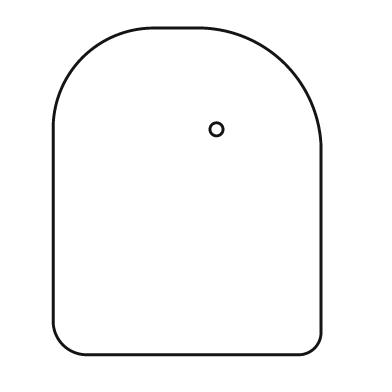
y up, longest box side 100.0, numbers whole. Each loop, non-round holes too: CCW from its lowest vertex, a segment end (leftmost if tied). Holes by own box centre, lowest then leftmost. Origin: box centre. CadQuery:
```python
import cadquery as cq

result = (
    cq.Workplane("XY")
    .moveTo(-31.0, -50.0)
    .lineTo(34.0, -50.0)
    .threePointArc((39.0, -48.0), (41.0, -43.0))
    .lineTo(41.0, 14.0)
    .threePointArc((30.0, 39.0), (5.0, 50.0))
    .lineTo(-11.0, 50.0)
    .threePointArc((-32.0, 41.0), (-41.0, 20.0))
    .lineTo(-41.0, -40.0)
    .threePointArc((-38.0, -47.0), (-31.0, -50.0))
    .close()
    .moveTo(9.0, 19.0)
    .circle(2.0)
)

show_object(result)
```